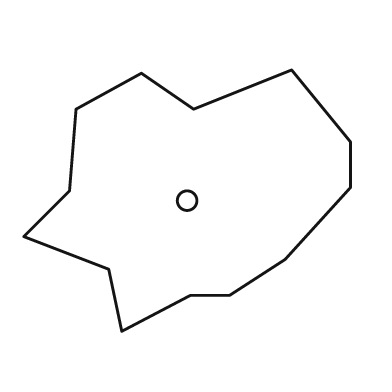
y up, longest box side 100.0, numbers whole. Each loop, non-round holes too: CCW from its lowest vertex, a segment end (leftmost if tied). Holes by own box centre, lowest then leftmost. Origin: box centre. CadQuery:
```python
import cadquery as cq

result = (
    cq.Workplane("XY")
    .moveTo(-20.0, -40.0)
    .lineTo(1.0, -29.0)
    .lineTo(13.0, -29.0)
    .lineTo(30.0, -18.0)
    .lineTo(50.0, 4.0)
    .lineTo(50.0, 18.0)
    .lineTo(32.0, 40.0)
    .lineTo(2.0, 28.0)
    .lineTo(-14.0, 39.0)
    .lineTo(-34.0, 28.0)
    .lineTo(-36.0, 3.0)
    .lineTo(-50.0, -11.0)
    .lineTo(-24.0, -21.0)
    .close()
    .moveTo(0.0, 0.0)
    .circle(3.0)
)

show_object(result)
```